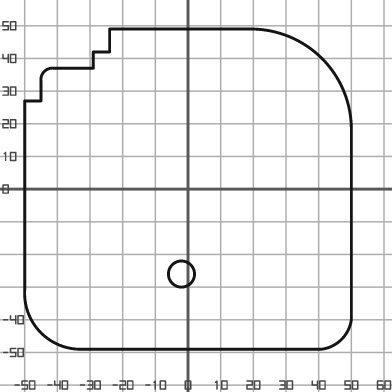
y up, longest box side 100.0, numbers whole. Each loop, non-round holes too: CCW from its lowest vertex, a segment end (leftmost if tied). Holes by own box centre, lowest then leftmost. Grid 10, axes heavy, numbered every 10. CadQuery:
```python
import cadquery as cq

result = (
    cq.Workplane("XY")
    .moveTo(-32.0, -49.0)
    .lineTo(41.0, -49.0)
    .threePointArc((47.0, -46.0), (50.0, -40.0))
    .lineTo(50.0, 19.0)
    .threePointArc((41.0, 40.0), (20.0, 49.0))
    .lineTo(-24.0, 49.0)
    .lineTo(-24.0, 42.0)
    .lineTo(-29.0, 42.0)
    .lineTo(-29.0, 37.0)
    .lineTo(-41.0, 37.0)
    .threePointArc((-44.0, 36.0), (-45.0, 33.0))
    .lineTo(-45.0, 27.0)
    .lineTo(-50.0, 27.0)
    .lineTo(-50.0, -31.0)
    .threePointArc((-45.0, -44.0), (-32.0, -49.0))
    .close()
    .moveTo(-2.0, -26.0)
    .circle(4.0)
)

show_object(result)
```